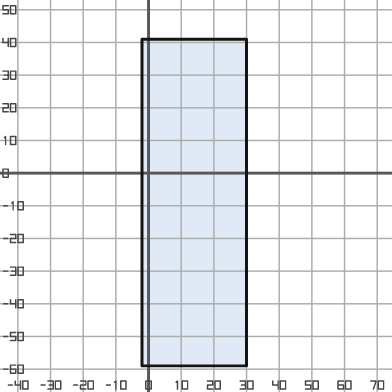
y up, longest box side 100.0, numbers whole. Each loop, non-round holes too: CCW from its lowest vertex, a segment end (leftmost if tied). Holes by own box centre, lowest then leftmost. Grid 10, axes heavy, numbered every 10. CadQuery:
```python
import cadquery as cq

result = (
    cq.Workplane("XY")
    .moveTo(-2.0, -59.0)
    .lineTo(30.0, -59.0)
    .lineTo(30.0, 41.0)
    .lineTo(-2.0, 41.0)
    .close()
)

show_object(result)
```